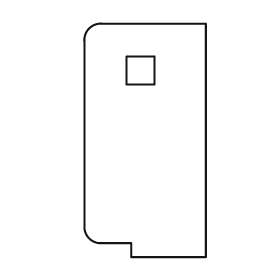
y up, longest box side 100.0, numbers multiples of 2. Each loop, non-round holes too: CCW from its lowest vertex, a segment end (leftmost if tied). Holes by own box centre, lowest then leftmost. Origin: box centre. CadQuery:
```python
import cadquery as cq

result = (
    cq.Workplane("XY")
    .moveTo(-6.0, -50.0)
    .lineTo(26.0, -50.0)
    .lineTo(26.0, 50.0)
    .lineTo(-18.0, 50.0)
    .threePointArc((-24.0, 48.0), (-26.0, 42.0))
    .lineTo(-26.0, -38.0)
    .threePointArc((-24.0, -42.0), (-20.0, -44.0))
    .lineTo(-6.0, -44.0)
    .close()
    .moveTo(-8.0, 24.0)
    .lineTo(4.0, 24.0)
    .lineTo(4.0, 36.0)
    .lineTo(-8.0, 36.0)
    .close()
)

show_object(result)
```